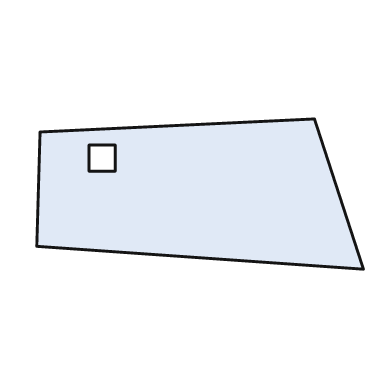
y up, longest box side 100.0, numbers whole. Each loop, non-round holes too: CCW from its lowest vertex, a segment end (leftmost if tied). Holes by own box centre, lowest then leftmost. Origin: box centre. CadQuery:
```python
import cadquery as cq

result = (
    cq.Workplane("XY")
    .moveTo(50.0, -23.0)
    .lineTo(35.0, 23.0)
    .lineTo(-49.0, 19.0)
    .lineTo(-50.0, -16.0)
    .close()
    .moveTo(-34.0, 7.0)
    .lineTo(-26.0, 7.0)
    .lineTo(-26.0, 15.0)
    .lineTo(-34.0, 15.0)
    .close()
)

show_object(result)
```